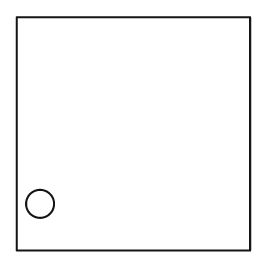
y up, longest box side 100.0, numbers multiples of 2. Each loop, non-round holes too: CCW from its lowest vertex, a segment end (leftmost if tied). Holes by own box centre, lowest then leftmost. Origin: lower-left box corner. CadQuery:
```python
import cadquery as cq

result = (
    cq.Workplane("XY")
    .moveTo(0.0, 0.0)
    .lineTo(100.0, 0.0)
    .lineTo(100.0, 100.0)
    .lineTo(0.0, 100.0)
    .close()
    .moveTo(10.0, 20.0)
    .circle(6.0)
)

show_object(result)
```